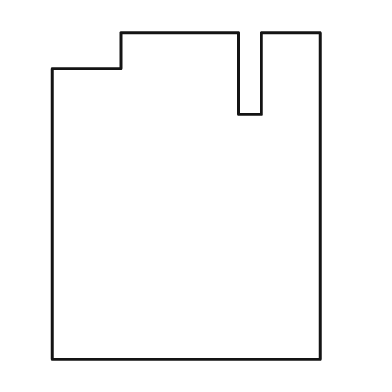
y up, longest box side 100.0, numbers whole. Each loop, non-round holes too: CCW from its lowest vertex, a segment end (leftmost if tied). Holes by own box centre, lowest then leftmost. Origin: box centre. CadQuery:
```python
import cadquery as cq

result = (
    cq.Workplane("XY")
    .moveTo(-41.0, -50.0)
    .lineTo(41.0, -50.0)
    .lineTo(41.0, 50.0)
    .lineTo(23.0, 50.0)
    .lineTo(23.0, 25.0)
    .lineTo(16.0, 25.0)
    .lineTo(16.0, 50.0)
    .lineTo(-20.0, 50.0)
    .lineTo(-20.0, 39.0)
    .lineTo(-41.0, 39.0)
    .close()
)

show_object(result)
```